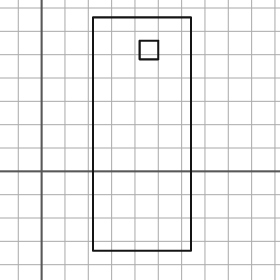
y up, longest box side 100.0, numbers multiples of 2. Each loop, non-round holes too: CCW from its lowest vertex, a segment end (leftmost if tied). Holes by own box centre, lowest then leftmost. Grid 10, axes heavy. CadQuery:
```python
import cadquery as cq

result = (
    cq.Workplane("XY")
    .moveTo(22.0, -34.0)
    .lineTo(64.0, -34.0)
    .lineTo(64.0, 66.0)
    .lineTo(22.0, 66.0)
    .close()
    .moveTo(42.0, 48.0)
    .lineTo(50.0, 48.0)
    .lineTo(50.0, 56.0)
    .lineTo(42.0, 56.0)
    .close()
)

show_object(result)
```